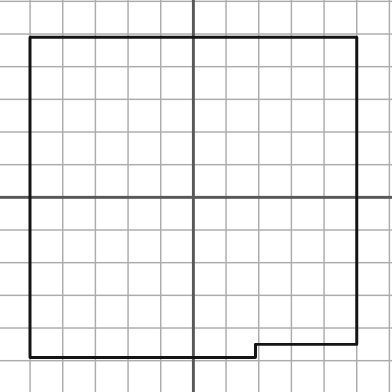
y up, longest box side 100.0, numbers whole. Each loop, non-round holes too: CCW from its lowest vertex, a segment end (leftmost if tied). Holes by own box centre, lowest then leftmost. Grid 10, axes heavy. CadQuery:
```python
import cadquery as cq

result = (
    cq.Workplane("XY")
    .moveTo(-50.0, -49.0)
    .lineTo(19.0, -49.0)
    .lineTo(19.0, -45.0)
    .lineTo(50.0, -45.0)
    .lineTo(50.0, 49.0)
    .lineTo(-50.0, 49.0)
    .close()
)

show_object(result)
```